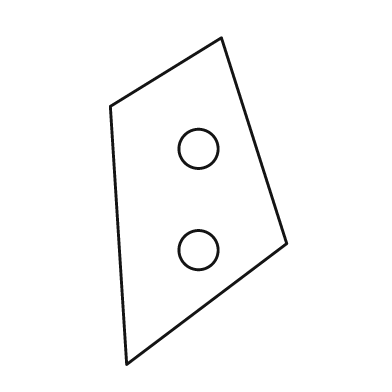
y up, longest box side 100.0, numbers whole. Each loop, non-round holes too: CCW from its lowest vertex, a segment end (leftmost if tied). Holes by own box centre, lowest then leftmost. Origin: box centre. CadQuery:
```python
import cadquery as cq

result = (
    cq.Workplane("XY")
    .moveTo(-22.0, -50.0)
    .lineTo(27.0, -13.0)
    .lineTo(7.0, 50.0)
    .lineTo(-27.0, 29.0)
    .close()
    .moveTo(0.0, -15.0)
    .circle(6.0)
    .moveTo(0.0, 16.0)
    .circle(6.0)
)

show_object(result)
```